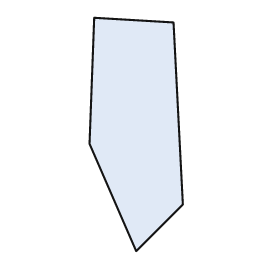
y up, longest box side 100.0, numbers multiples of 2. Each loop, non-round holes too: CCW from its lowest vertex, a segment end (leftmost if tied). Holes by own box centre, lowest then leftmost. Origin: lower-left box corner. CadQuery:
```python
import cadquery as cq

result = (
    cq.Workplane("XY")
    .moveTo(20.0, 0.0)
    .lineTo(40.0, 20.0)
    .lineTo(36.0, 98.0)
    .lineTo(2.0, 100.0)
    .lineTo(0.0, 46.0)
    .close()
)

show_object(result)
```